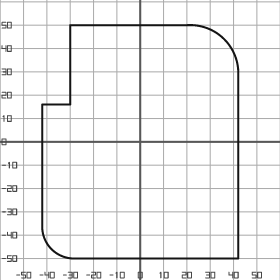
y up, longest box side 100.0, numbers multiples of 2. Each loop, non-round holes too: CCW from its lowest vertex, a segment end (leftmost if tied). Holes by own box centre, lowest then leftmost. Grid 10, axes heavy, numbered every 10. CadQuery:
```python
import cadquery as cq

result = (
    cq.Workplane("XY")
    .moveTo(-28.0, -50.0)
    .lineTo(42.0, -50.0)
    .lineTo(42.0, 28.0)
    .threePointArc((36.0, 44.0), (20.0, 50.0))
    .lineTo(-30.0, 50.0)
    .lineTo(-30.0, 16.0)
    .lineTo(-42.0, 16.0)
    .lineTo(-42.0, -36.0)
    .threePointArc((-38.0, -46.0), (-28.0, -50.0))
    .close()
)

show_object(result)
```